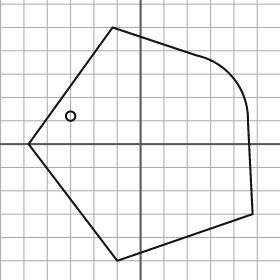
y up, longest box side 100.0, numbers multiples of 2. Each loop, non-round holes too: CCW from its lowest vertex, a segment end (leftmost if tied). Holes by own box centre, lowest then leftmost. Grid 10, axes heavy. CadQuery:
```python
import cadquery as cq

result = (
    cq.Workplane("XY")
    .moveTo(-10.0, -50.0)
    .lineTo(48.0, -30.0)
    .lineTo(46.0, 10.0)
    .threePointArc((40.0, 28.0), (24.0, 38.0))
    .lineTo(-12.0, 50.0)
    .lineTo(-48.0, 0.0)
    .close()
    .moveTo(-30.0, 12.0)
    .circle(2.0)
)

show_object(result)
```